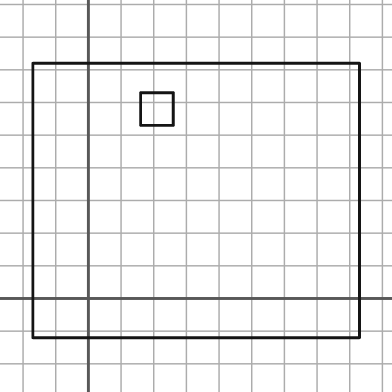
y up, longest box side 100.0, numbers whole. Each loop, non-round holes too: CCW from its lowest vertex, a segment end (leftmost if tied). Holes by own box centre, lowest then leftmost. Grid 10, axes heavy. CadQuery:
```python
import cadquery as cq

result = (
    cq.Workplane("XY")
    .moveTo(-17.0, -12.0)
    .lineTo(83.0, -12.0)
    .lineTo(83.0, 72.0)
    .lineTo(-17.0, 72.0)
    .close()
    .moveTo(16.0, 53.0)
    .lineTo(26.0, 53.0)
    .lineTo(26.0, 63.0)
    .lineTo(16.0, 63.0)
    .close()
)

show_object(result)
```